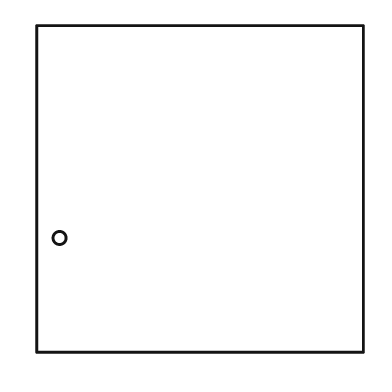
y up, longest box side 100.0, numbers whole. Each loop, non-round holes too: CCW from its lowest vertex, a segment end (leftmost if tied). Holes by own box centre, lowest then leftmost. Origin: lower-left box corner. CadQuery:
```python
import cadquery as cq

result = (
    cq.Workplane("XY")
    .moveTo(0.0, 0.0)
    .lineTo(100.0, 0.0)
    .lineTo(100.0, 100.0)
    .lineTo(0.0, 100.0)
    .close()
    .moveTo(7.0, 35.0)
    .circle(2.0)
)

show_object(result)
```